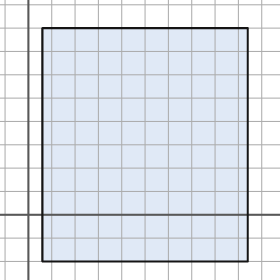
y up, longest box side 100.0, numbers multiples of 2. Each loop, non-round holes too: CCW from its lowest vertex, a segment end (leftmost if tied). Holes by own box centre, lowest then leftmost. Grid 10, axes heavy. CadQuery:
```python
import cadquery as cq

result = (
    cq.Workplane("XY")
    .moveTo(6.0, -20.0)
    .lineTo(94.0, -20.0)
    .lineTo(94.0, 80.0)
    .lineTo(6.0, 80.0)
    .close()
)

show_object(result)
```